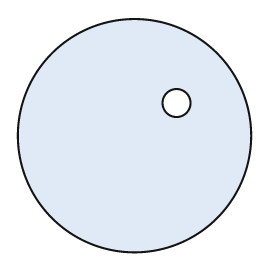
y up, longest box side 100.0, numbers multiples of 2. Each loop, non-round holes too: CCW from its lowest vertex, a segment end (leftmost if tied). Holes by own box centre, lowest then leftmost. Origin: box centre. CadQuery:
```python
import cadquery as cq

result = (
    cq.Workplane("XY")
    .moveTo(0.0, 0.0)
    .circle(50.0)
    .moveTo(18.0, 14.0)
    .circle(6.0)
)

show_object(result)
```